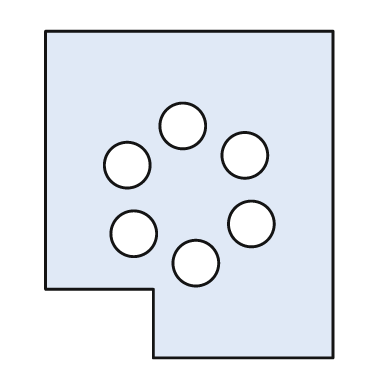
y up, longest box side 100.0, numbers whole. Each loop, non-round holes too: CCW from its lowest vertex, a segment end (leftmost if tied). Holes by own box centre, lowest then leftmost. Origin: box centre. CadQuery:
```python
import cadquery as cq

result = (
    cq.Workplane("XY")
    .moveTo(-11.0, -50.0)
    .lineTo(44.0, -50.0)
    .lineTo(44.0, 50.0)
    .lineTo(-44.0, 50.0)
    .lineTo(-44.0, -29.0)
    .lineTo(-11.0, -29.0)
    .close()
    .moveTo(2.0, -21.0)
    .circle(7.0)
    .moveTo(-17.0, -12.0)
    .circle(7.0)
    .moveTo(19.0, -9.0)
    .circle(7.0)
    .moveTo(-19.0, 9.0)
    .circle(7.0)
    .moveTo(17.0, 12.0)
    .circle(7.0)
    .moveTo(-2.0, 21.0)
    .circle(7.0)
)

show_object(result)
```